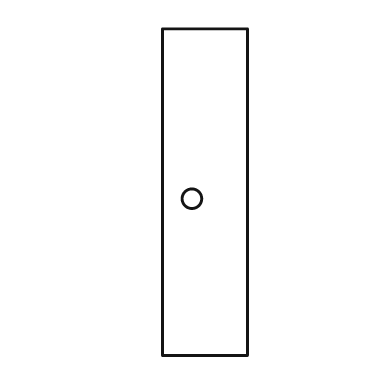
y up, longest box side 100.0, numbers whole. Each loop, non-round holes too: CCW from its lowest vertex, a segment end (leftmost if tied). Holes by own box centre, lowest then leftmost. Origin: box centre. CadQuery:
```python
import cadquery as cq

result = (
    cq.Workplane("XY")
    .moveTo(-13.0, -50.0)
    .lineTo(13.0, -50.0)
    .lineTo(13.0, 50.0)
    .lineTo(-13.0, 50.0)
    .close()
    .moveTo(-4.0, -2.0)
    .circle(3.0)
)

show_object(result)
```